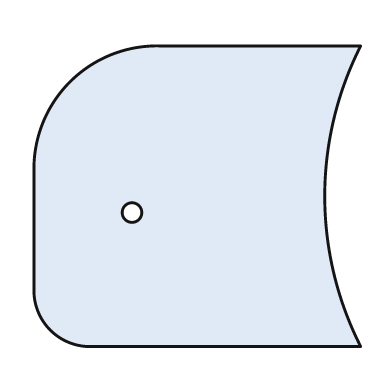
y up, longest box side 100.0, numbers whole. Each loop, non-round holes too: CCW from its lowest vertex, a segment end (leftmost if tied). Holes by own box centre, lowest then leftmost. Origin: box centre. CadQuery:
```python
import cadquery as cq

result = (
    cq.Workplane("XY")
    .moveTo(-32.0, -46.0)
    .lineTo(50.0, -46.0)
    .threePointArc((39.0, 0.0), (50.0, 46.0))
    .lineTo(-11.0, 46.0)
    .threePointArc((-39.0, 35.0), (-50.0, 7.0))
    .lineTo(-50.0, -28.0)
    .threePointArc((-45.0, -41.0), (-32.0, -46.0))
    .close()
    .moveTo(-20.0, -5.0)
    .circle(3.0)
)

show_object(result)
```